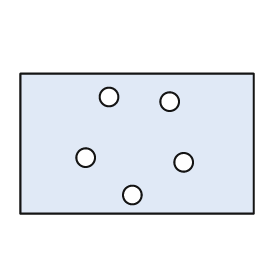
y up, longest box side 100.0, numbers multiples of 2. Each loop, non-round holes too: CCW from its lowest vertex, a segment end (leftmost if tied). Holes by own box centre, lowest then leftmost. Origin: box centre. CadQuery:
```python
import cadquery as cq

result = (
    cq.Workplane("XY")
    .moveTo(-50.0, -30.0)
    .lineTo(50.0, -30.0)
    .lineTo(50.0, 30.0)
    .lineTo(-50.0, 30.0)
    .close()
    .moveTo(-2.0, -22.0)
    .circle(4.0)
    .moveTo(20.0, -8.0)
    .circle(4.0)
    .moveTo(-22.0, -6.0)
    .circle(4.0)
    .moveTo(14.0, 18.0)
    .circle(4.0)
    .moveTo(-12.0, 20.0)
    .circle(4.0)
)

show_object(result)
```